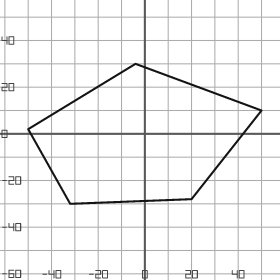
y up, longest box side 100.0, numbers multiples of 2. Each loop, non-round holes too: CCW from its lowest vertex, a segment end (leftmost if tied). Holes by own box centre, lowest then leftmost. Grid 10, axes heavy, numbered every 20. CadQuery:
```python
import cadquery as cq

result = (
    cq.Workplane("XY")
    .moveTo(-32.0, -30.0)
    .lineTo(20.0, -28.0)
    .lineTo(50.0, 10.0)
    .lineTo(-4.0, 30.0)
    .lineTo(-50.0, 2.0)
    .close()
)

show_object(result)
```